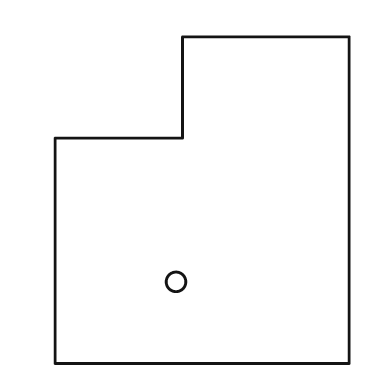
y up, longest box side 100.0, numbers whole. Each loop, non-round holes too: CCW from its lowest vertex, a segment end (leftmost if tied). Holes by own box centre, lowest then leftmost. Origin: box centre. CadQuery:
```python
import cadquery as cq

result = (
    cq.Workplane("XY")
    .moveTo(-45.0, -50.0)
    .lineTo(45.0, -50.0)
    .lineTo(45.0, 50.0)
    .lineTo(-6.0, 50.0)
    .lineTo(-6.0, 19.0)
    .lineTo(-45.0, 19.0)
    .close()
    .moveTo(-8.0, -25.0)
    .circle(3.0)
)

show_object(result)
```